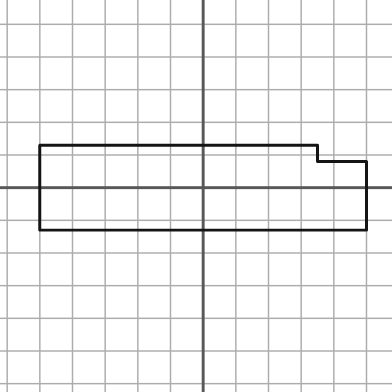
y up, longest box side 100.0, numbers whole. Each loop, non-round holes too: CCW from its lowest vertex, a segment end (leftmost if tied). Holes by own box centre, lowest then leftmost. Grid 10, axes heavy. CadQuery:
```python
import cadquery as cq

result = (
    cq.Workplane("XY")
    .moveTo(-50.0, -13.0)
    .lineTo(50.0, -13.0)
    .lineTo(50.0, 8.0)
    .lineTo(35.0, 8.0)
    .lineTo(35.0, 13.0)
    .lineTo(-50.0, 13.0)
    .close()
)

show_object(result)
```